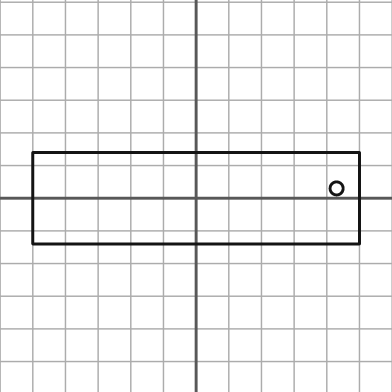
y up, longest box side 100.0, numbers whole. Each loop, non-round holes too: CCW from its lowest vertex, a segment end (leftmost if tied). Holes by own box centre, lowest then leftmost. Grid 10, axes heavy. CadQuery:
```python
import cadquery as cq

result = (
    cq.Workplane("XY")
    .moveTo(-50.0, -14.0)
    .lineTo(50.0, -14.0)
    .lineTo(50.0, 14.0)
    .lineTo(-50.0, 14.0)
    .close()
    .moveTo(43.0, 3.0)
    .circle(2.0)
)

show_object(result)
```